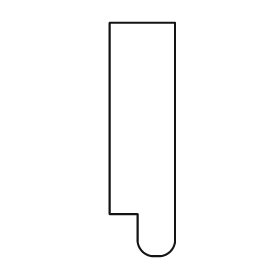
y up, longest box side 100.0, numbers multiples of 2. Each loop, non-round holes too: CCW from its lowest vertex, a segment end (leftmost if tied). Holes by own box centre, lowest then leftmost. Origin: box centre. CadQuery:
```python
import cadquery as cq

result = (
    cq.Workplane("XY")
    .moveTo(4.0, -50.0)
    .lineTo(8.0, -50.0)
    .threePointArc((12.0, -48.0), (14.0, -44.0))
    .lineTo(14.0, 50.0)
    .lineTo(-14.0, 50.0)
    .lineTo(-14.0, -32.0)
    .lineTo(-2.0, -32.0)
    .lineTo(-2.0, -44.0)
    .threePointArc((0.0, -48.0), (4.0, -50.0))
    .close()
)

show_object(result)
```